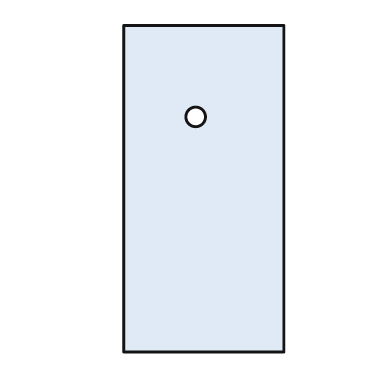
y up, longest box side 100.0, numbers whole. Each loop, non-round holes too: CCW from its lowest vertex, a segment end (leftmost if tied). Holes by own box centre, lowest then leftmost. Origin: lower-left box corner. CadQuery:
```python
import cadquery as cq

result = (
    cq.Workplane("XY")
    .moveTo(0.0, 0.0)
    .lineTo(49.0, 0.0)
    .lineTo(49.0, 100.0)
    .lineTo(0.0, 100.0)
    .close()
    .moveTo(22.0, 72.0)
    .circle(3.0)
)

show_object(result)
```